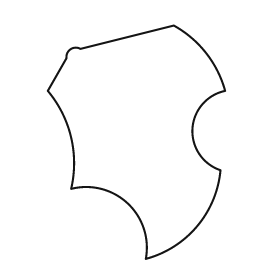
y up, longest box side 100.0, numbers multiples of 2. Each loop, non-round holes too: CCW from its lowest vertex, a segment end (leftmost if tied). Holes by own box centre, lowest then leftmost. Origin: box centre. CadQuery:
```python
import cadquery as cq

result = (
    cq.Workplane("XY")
    .moveTo(4.0, -50.0)
    .threePointArc((26.0, -36.0), (36.0, -12.0))
    .threePointArc((24.0, 6.0), (38.0, 22.0))
    .threePointArc((30.0, 38.0), (16.0, 50.0))
    .lineTo(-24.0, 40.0)
    .threePointArc((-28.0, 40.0), (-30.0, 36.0))
    .lineTo(-38.0, 22.0)
    .threePointArc((-28.0, 2.0), (-28.0, -20.0))
    .threePointArc((-4.0, -26.0), (4.0, -50.0))
    .close()
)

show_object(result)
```